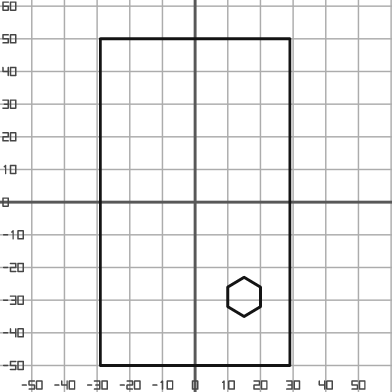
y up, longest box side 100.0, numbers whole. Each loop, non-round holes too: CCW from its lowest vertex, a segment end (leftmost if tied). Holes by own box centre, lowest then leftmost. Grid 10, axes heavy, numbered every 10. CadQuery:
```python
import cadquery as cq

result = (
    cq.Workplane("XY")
    .moveTo(-29.0, -50.0)
    .lineTo(29.0, -50.0)
    .lineTo(29.0, 50.0)
    .lineTo(-29.0, 50.0)
    .close()
    .moveTo(15.0, -35.0)
    .lineTo(20.0, -32.0)
    .lineTo(20.0, -26.0)
    .lineTo(15.0, -23.0)
    .lineTo(10.0, -26.0)
    .lineTo(10.0, -32.0)
    .close()
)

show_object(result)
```